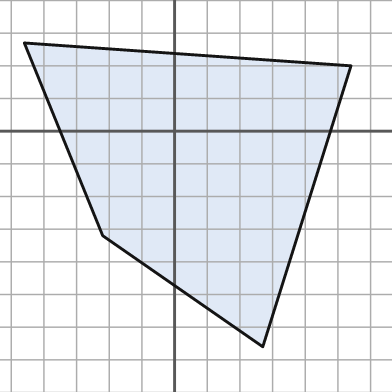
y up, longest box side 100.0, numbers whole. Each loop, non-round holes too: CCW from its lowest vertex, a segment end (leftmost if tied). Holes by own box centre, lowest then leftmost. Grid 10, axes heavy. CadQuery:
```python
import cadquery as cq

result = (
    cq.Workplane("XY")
    .moveTo(27.0, -66.0)
    .lineTo(54.0, 20.0)
    .lineTo(-46.0, 27.0)
    .lineTo(-22.0, -32.0)
    .close()
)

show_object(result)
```